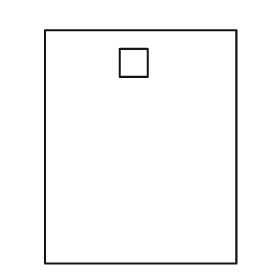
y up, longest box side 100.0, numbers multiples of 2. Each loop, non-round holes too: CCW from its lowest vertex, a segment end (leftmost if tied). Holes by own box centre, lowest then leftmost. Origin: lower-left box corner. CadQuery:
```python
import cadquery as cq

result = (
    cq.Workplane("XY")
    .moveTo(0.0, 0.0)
    .lineTo(82.0, 0.0)
    .lineTo(82.0, 100.0)
    .lineTo(0.0, 100.0)
    .close()
    .moveTo(32.0, 80.0)
    .lineTo(44.0, 80.0)
    .lineTo(44.0, 92.0)
    .lineTo(32.0, 92.0)
    .close()
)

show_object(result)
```